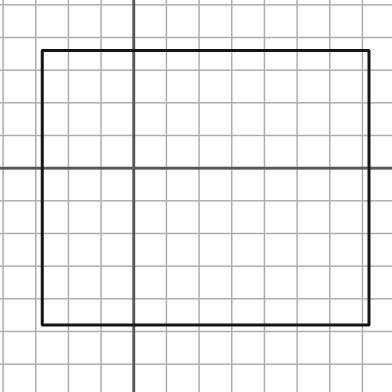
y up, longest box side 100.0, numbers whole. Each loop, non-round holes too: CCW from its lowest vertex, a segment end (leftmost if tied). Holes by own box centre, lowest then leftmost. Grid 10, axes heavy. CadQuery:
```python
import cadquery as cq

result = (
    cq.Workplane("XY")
    .moveTo(-28.0, -48.0)
    .lineTo(72.0, -48.0)
    .lineTo(72.0, 36.0)
    .lineTo(-28.0, 36.0)
    .close()
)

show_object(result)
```